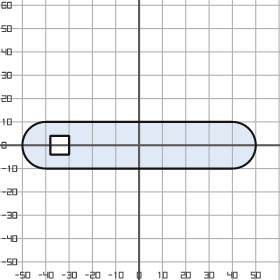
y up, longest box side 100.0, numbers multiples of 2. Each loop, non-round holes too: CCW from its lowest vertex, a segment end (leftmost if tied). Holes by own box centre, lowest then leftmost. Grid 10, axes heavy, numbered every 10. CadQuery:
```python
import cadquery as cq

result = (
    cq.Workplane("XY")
    .moveTo(-40.0, -10.0)
    .lineTo(40.0, -10.0)
    .threePointArc((50.0, 0.0), (40.0, 10.0))
    .lineTo(-40.0, 10.0)
    .threePointArc((-50.0, 0.0), (-40.0, -10.0))
    .close()
    .moveTo(-38.0, -4.0)
    .lineTo(-30.0, -4.0)
    .lineTo(-30.0, 4.0)
    .lineTo(-38.0, 4.0)
    .close()
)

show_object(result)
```